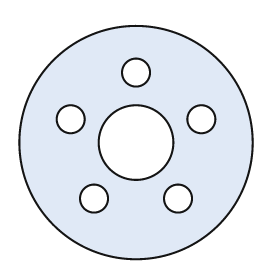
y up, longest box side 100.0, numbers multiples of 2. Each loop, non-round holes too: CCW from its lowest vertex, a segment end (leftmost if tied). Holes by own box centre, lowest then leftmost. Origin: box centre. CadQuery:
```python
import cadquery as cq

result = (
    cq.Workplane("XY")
    .moveTo(0.0, 0.0)
    .circle(50.0)
    .moveTo(-18.0, -24.0)
    .circle(6.0)
    .moveTo(18.0, -24.0)
    .circle(6.0)
    .moveTo(0.0, 0.0)
    .circle(16.0)
    .moveTo(-28.0, 10.0)
    .circle(6.0)
    .moveTo(28.0, 10.0)
    .circle(6.0)
    .moveTo(0.0, 30.0)
    .circle(6.0)
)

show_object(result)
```